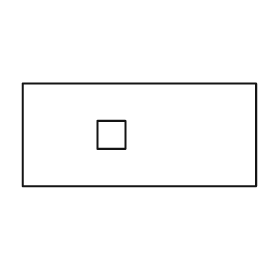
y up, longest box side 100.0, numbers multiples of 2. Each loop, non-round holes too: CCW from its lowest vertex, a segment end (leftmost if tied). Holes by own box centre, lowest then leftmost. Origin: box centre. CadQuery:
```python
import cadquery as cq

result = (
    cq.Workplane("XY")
    .moveTo(-50.0, -22.0)
    .lineTo(50.0, -22.0)
    .lineTo(50.0, 22.0)
    .lineTo(-50.0, 22.0)
    .close()
    .moveTo(-18.0, -6.0)
    .lineTo(-6.0, -6.0)
    .lineTo(-6.0, 6.0)
    .lineTo(-18.0, 6.0)
    .close()
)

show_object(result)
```